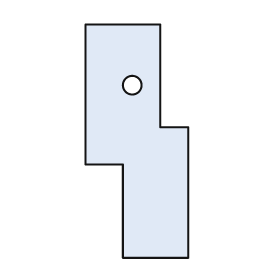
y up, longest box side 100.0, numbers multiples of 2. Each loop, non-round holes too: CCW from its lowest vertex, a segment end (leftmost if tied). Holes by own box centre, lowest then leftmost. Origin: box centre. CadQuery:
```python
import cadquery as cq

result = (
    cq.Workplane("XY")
    .moveTo(-6.0, -50.0)
    .lineTo(22.0, -50.0)
    .lineTo(22.0, 6.0)
    .lineTo(10.0, 6.0)
    .lineTo(10.0, 50.0)
    .lineTo(-22.0, 50.0)
    .lineTo(-22.0, -10.0)
    .lineTo(-6.0, -10.0)
    .close()
    .moveTo(-2.0, 24.0)
    .circle(4.0)
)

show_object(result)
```